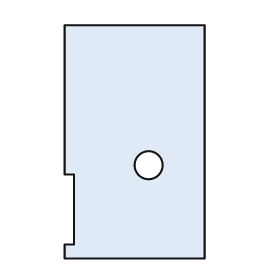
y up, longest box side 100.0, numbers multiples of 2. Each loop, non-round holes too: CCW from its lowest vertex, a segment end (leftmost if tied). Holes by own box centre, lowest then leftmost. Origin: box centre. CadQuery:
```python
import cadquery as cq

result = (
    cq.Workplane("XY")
    .moveTo(-30.0, -50.0)
    .lineTo(30.0, -50.0)
    .lineTo(30.0, 50.0)
    .lineTo(-30.0, 50.0)
    .lineTo(-30.0, -14.0)
    .lineTo(-26.0, -14.0)
    .lineTo(-26.0, -44.0)
    .lineTo(-30.0, -44.0)
    .close()
    .moveTo(6.0, -10.0)
    .circle(6.0)
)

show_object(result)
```